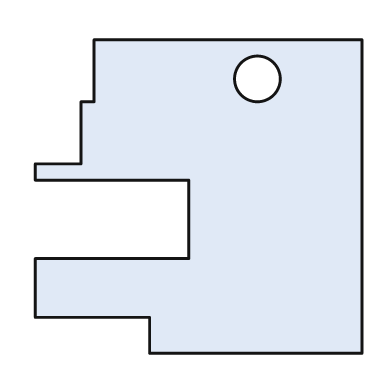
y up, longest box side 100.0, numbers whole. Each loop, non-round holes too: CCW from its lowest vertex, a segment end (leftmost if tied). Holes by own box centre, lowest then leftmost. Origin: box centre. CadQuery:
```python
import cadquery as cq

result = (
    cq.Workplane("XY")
    .moveTo(-15.0, -48.0)
    .lineTo(50.0, -48.0)
    .lineTo(50.0, 48.0)
    .lineTo(-32.0, 48.0)
    .lineTo(-32.0, 29.0)
    .lineTo(-36.0, 29.0)
    .lineTo(-36.0, 10.0)
    .lineTo(-50.0, 10.0)
    .lineTo(-50.0, 5.0)
    .lineTo(-3.0, 5.0)
    .lineTo(-3.0, -19.0)
    .lineTo(-50.0, -19.0)
    .lineTo(-50.0, -37.0)
    .lineTo(-15.0, -37.0)
    .close()
    .moveTo(18.0, 36.0)
    .circle(7.0)
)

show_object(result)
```